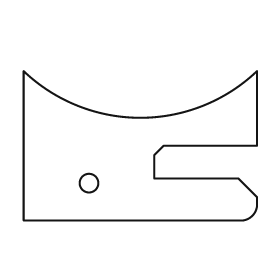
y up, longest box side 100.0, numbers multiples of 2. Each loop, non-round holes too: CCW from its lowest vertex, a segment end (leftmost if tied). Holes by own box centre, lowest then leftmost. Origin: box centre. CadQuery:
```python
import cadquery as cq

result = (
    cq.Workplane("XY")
    .moveTo(-50.0, -32.0)
    .lineTo(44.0, -32.0)
    .threePointArc((48.0, -30.0), (50.0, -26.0))
    .lineTo(50.0, -22.0)
    .lineTo(42.0, -14.0)
    .lineTo(6.0, -14.0)
    .lineTo(6.0, -4.0)
    .lineTo(10.0, 0.0)
    .lineTo(50.0, 0.0)
    .lineTo(50.0, 32.0)
    .threePointArc((0.0, 12.0), (-50.0, 32.0))
    .close()
    .moveTo(-22.0, -16.0)
    .circle(4.0)
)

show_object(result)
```